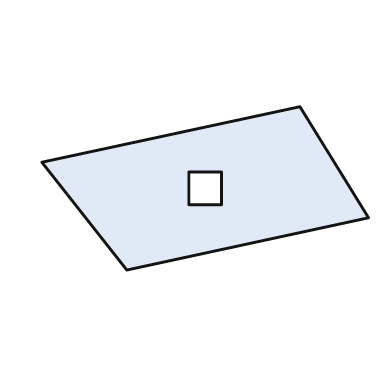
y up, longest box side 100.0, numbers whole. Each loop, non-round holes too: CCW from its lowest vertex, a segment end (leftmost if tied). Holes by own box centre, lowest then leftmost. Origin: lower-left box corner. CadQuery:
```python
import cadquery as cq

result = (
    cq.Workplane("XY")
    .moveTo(26.0, 0.0)
    .lineTo(100.0, 16.0)
    .lineTo(79.0, 50.0)
    .lineTo(0.0, 33.0)
    .close()
    .moveTo(45.0, 20.0)
    .lineTo(55.0, 20.0)
    .lineTo(55.0, 30.0)
    .lineTo(45.0, 30.0)
    .close()
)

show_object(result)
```